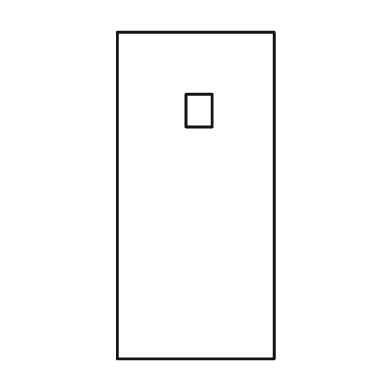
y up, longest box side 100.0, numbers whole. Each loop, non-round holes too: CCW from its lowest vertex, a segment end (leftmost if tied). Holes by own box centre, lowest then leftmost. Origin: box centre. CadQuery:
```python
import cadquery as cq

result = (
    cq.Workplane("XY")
    .moveTo(-24.0, -50.0)
    .lineTo(24.0, -50.0)
    .lineTo(24.0, 50.0)
    .lineTo(-24.0, 50.0)
    .close()
    .moveTo(-3.0, 21.0)
    .lineTo(5.0, 21.0)
    .lineTo(5.0, 31.0)
    .lineTo(-3.0, 31.0)
    .close()
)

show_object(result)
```